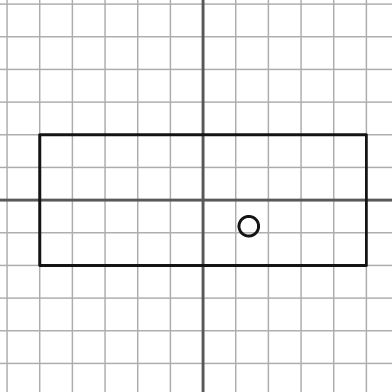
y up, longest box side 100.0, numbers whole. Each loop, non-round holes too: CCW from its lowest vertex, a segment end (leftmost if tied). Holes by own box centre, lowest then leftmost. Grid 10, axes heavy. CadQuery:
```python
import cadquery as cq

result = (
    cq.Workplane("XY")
    .moveTo(-50.0, -20.0)
    .lineTo(50.0, -20.0)
    .lineTo(50.0, 20.0)
    .lineTo(-50.0, 20.0)
    .close()
    .moveTo(14.0, -8.0)
    .circle(3.0)
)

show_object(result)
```